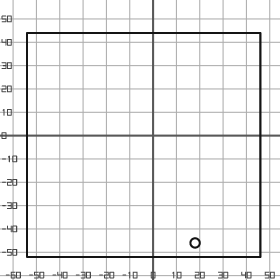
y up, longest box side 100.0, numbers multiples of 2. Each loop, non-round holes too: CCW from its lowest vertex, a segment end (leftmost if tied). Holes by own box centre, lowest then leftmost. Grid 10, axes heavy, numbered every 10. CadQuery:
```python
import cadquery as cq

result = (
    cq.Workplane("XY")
    .moveTo(-54.0, -52.0)
    .lineTo(46.0, -52.0)
    .lineTo(46.0, 44.0)
    .lineTo(-54.0, 44.0)
    .close()
    .moveTo(18.0, -46.0)
    .circle(2.0)
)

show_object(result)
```